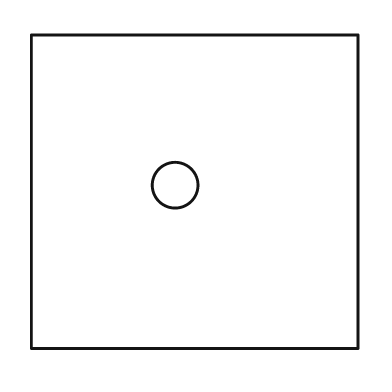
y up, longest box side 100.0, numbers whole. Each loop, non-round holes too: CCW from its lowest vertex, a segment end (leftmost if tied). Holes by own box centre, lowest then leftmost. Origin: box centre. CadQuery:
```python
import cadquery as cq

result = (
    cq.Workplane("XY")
    .moveTo(-50.0, -48.0)
    .lineTo(50.0, -48.0)
    .lineTo(50.0, 48.0)
    .lineTo(-50.0, 48.0)
    .close()
    .moveTo(-6.0, 2.0)
    .circle(7.0)
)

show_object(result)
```